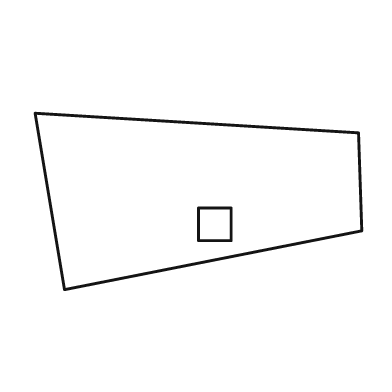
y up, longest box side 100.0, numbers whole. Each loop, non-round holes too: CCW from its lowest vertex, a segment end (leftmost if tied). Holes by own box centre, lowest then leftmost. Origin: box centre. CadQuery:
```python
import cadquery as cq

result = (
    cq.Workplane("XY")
    .moveTo(-41.0, -27.0)
    .lineTo(50.0, -9.0)
    .lineTo(49.0, 21.0)
    .lineTo(-50.0, 27.0)
    .close()
    .moveTo(0.0, -12.0)
    .lineTo(10.0, -12.0)
    .lineTo(10.0, -2.0)
    .lineTo(0.0, -2.0)
    .close()
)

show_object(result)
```